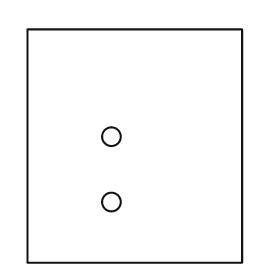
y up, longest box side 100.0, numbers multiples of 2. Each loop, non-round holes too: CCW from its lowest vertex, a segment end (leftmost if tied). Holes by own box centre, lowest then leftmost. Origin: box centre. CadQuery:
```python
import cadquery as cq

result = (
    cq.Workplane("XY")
    .moveTo(-46.0, -50.0)
    .lineTo(46.0, -50.0)
    .lineTo(46.0, 50.0)
    .lineTo(-46.0, 50.0)
    .close()
    .moveTo(-10.0, -24.0)
    .circle(4.0)
    .moveTo(-10.0, 4.0)
    .circle(4.0)
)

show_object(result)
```